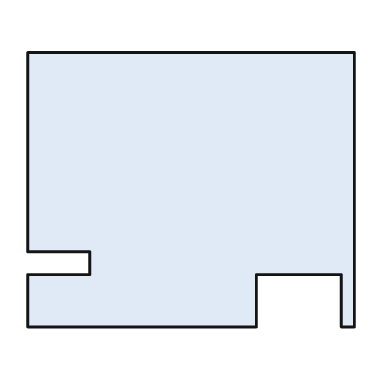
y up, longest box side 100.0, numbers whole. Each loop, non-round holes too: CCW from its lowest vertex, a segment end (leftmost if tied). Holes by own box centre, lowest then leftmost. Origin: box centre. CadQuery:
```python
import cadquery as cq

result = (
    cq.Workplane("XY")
    .moveTo(-50.0, -42.0)
    .lineTo(20.0, -42.0)
    .lineTo(20.0, -26.0)
    .lineTo(46.0, -26.0)
    .lineTo(46.0, -42.0)
    .lineTo(50.0, -42.0)
    .lineTo(50.0, 42.0)
    .lineTo(-50.0, 42.0)
    .lineTo(-50.0, -19.0)
    .lineTo(-31.0, -19.0)
    .lineTo(-31.0, -26.0)
    .lineTo(-50.0, -26.0)
    .close()
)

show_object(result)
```